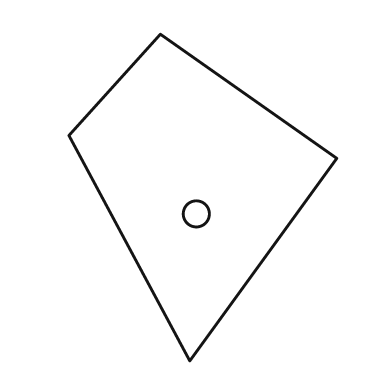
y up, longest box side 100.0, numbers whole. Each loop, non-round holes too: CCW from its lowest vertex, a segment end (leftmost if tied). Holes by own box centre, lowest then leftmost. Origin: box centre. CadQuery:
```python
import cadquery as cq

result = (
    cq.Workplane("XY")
    .moveTo(-4.0, -50.0)
    .lineTo(41.0, 12.0)
    .lineTo(-13.0, 50.0)
    .lineTo(-41.0, 19.0)
    .close()
    .moveTo(-2.0, -5.0)
    .circle(4.0)
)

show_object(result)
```